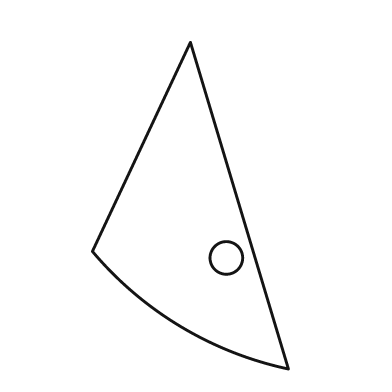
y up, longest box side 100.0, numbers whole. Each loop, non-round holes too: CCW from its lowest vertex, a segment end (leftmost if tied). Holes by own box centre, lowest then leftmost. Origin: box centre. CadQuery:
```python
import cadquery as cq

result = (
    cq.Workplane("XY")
    .moveTo(30.0, -50.0)
    .lineTo(0.0, 50.0)
    .lineTo(-30.0, -14.0)
    .threePointArc((-3.0, -37.0), (30.0, -50.0))
    .close()
    .moveTo(11.0, -16.0)
    .circle(5.0)
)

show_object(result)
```